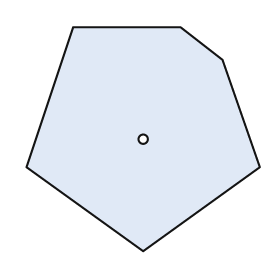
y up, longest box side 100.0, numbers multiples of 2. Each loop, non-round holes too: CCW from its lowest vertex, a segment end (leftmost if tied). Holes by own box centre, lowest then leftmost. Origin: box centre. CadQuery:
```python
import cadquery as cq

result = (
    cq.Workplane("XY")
    .moveTo(0.0, -48.0)
    .lineTo(50.0, -12.0)
    .lineTo(34.0, 34.0)
    .lineTo(16.0, 48.0)
    .lineTo(-30.0, 48.0)
    .lineTo(-50.0, -12.0)
    .close()
    .moveTo(0.0, 0.0)
    .circle(2.0)
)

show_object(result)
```